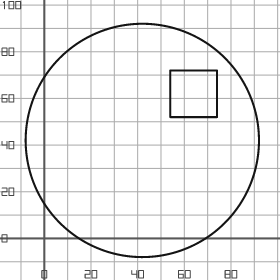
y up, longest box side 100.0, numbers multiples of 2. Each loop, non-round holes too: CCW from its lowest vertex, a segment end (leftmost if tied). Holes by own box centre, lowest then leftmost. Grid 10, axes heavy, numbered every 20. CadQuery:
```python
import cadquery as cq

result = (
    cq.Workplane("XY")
    .moveTo(42.0, 42.0)
    .circle(50.0)
    .moveTo(54.0, 52.0)
    .lineTo(74.0, 52.0)
    .lineTo(74.0, 72.0)
    .lineTo(54.0, 72.0)
    .close()
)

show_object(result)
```